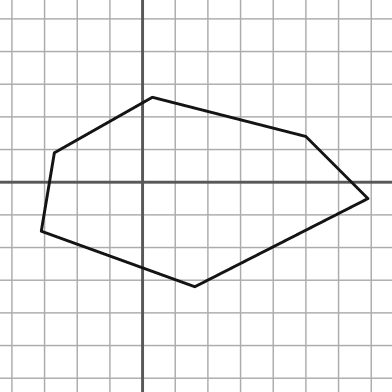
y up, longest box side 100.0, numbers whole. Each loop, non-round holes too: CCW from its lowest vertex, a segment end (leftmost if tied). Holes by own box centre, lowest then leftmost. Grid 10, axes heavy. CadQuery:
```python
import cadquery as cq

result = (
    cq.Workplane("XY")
    .moveTo(16.0, -32.0)
    .lineTo(69.0, -5.0)
    .lineTo(50.0, 14.0)
    .lineTo(3.0, 26.0)
    .lineTo(-27.0, 9.0)
    .lineTo(-31.0, -15.0)
    .close()
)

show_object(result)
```